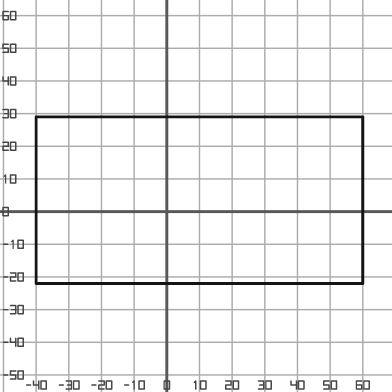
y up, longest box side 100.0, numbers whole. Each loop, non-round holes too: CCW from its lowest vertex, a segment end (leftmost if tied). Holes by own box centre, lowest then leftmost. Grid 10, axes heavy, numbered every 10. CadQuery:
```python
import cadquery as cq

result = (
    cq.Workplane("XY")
    .moveTo(-40.0, -22.0)
    .lineTo(60.0, -22.0)
    .lineTo(60.0, 29.0)
    .lineTo(-40.0, 29.0)
    .close()
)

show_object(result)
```